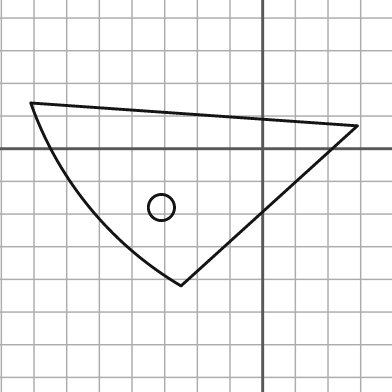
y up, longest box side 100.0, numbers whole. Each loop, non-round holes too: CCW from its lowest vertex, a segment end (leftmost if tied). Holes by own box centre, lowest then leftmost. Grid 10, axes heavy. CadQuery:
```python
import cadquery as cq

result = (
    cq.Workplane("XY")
    .moveTo(-25.0, -42.0)
    .lineTo(29.0, 7.0)
    .lineTo(-71.0, 14.0)
    .threePointArc((-53.0, -18.0), (-25.0, -42.0))
    .close()
    .moveTo(-31.0, -18.0)
    .circle(4.0)
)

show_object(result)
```